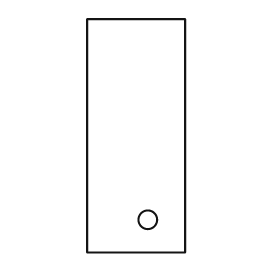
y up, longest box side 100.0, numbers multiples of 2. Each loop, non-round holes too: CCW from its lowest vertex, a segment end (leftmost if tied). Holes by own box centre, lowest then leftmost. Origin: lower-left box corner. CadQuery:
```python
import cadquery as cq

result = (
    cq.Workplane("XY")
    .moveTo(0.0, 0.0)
    .lineTo(42.0, 0.0)
    .lineTo(42.0, 100.0)
    .lineTo(0.0, 100.0)
    .close()
    .moveTo(26.0, 14.0)
    .circle(4.0)
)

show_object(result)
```